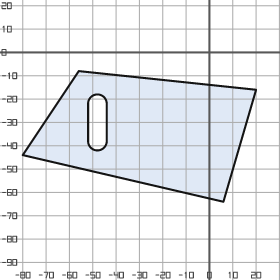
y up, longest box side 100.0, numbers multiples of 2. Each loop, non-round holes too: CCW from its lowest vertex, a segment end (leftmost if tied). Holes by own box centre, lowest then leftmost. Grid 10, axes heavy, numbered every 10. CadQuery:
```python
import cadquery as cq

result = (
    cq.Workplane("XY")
    .moveTo(6.0, -64.0)
    .lineTo(20.0, -16.0)
    .lineTo(-56.0, -8.0)
    .lineTo(-80.0, -44.0)
    .close()
    .moveTo(-52.0, -38.0)
    .threePointArc((-48.0, -42.0), (-44.0, -38.0))
    .lineTo(-44.0, -22.0)
    .threePointArc((-48.0, -18.0), (-52.0, -22.0))
    .close()
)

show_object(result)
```